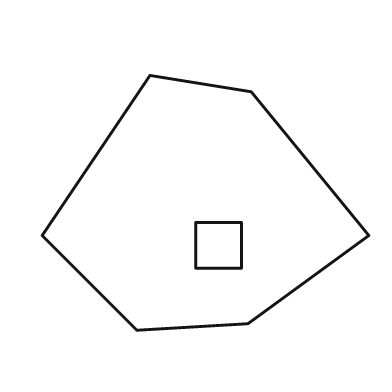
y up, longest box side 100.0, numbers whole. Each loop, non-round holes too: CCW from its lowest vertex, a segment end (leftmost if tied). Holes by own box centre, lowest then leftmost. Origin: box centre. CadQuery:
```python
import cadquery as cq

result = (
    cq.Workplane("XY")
    .moveTo(-21.0, -39.0)
    .lineTo(13.0, -37.0)
    .lineTo(50.0, -10.0)
    .lineTo(14.0, 34.0)
    .lineTo(-17.0, 39.0)
    .lineTo(-50.0, -10.0)
    .close()
    .moveTo(-3.0, -20.0)
    .lineTo(11.0, -20.0)
    .lineTo(11.0, -6.0)
    .lineTo(-3.0, -6.0)
    .close()
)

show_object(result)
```